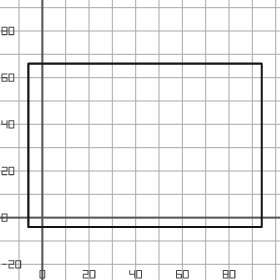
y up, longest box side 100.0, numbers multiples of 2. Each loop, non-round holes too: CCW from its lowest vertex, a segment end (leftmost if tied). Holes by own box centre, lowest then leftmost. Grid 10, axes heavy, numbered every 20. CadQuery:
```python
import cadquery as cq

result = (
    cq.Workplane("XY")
    .moveTo(-6.0, -4.0)
    .lineTo(94.0, -4.0)
    .lineTo(94.0, 66.0)
    .lineTo(-6.0, 66.0)
    .close()
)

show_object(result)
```